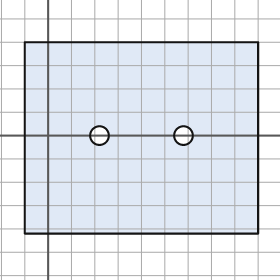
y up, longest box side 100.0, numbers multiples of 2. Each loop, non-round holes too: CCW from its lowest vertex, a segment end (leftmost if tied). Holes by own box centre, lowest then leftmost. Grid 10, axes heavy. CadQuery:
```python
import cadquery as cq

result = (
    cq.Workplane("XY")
    .moveTo(-10.0, -42.0)
    .lineTo(90.0, -42.0)
    .lineTo(90.0, 40.0)
    .lineTo(-10.0, 40.0)
    .close()
    .moveTo(22.0, 0.0)
    .circle(4.0)
    .moveTo(58.0, 0.0)
    .circle(4.0)
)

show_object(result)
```